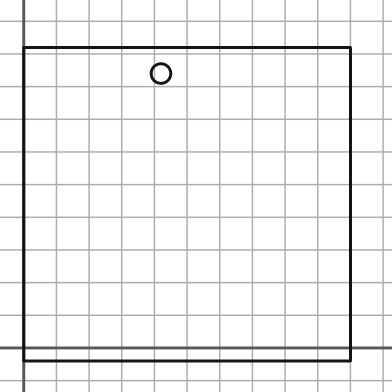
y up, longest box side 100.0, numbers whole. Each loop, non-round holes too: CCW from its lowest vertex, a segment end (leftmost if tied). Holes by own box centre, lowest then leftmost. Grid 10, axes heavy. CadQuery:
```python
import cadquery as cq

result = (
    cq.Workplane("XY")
    .moveTo(0.0, -4.0)
    .lineTo(100.0, -4.0)
    .lineTo(100.0, 92.0)
    .lineTo(0.0, 92.0)
    .close()
    .moveTo(42.0, 84.0)
    .circle(3.0)
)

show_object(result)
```